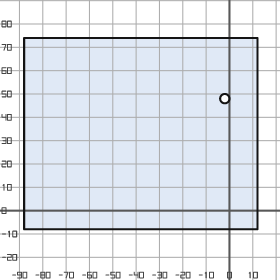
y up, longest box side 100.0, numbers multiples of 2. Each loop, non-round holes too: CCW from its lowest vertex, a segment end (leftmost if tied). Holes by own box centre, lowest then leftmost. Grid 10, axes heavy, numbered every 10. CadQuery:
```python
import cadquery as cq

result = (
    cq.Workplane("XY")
    .moveTo(-88.0, -8.0)
    .lineTo(12.0, -8.0)
    .lineTo(12.0, 74.0)
    .lineTo(-88.0, 74.0)
    .close()
    .moveTo(-2.0, 48.0)
    .circle(2.0)
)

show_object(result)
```